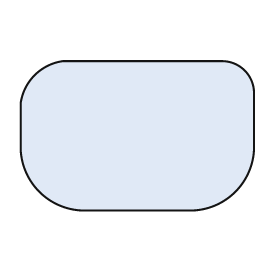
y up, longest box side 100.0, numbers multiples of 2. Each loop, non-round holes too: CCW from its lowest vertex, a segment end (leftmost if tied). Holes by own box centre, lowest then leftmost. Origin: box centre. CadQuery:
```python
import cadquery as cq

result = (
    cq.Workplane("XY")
    .moveTo(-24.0, -32.0)
    .lineTo(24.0, -32.0)
    .threePointArc((42.0, -24.0), (50.0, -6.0))
    .lineTo(50.0, 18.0)
    .threePointArc((46.0, 28.0), (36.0, 32.0))
    .lineTo(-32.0, 32.0)
    .threePointArc((-44.0, 26.0), (-50.0, 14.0))
    .lineTo(-50.0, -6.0)
    .threePointArc((-42.0, -24.0), (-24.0, -32.0))
    .close()
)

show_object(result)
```